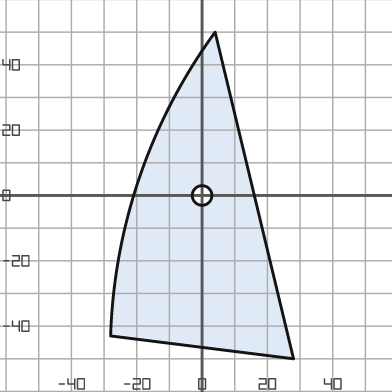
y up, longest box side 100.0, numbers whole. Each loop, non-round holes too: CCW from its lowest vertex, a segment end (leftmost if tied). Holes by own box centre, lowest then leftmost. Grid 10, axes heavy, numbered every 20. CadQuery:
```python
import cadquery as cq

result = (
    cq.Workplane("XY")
    .moveTo(28.0, -50.0)
    .lineTo(4.0, 50.0)
    .threePointArc((-19.0, 6.0), (-28.0, -43.0))
    .close()
    .moveTo(0.0, 0.0)
    .circle(3.0)
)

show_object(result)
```